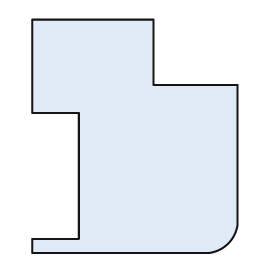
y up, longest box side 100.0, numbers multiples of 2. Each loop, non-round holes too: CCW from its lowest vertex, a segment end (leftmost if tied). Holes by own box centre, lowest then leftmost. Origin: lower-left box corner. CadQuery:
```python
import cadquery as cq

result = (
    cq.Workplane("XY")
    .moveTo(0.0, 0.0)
    .lineTo(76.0, 0.0)
    .threePointArc((84.0, 4.0), (88.0, 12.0))
    .lineTo(88.0, 72.0)
    .lineTo(52.0, 72.0)
    .lineTo(52.0, 100.0)
    .lineTo(0.0, 100.0)
    .lineTo(0.0, 60.0)
    .lineTo(20.0, 60.0)
    .lineTo(20.0, 6.0)
    .lineTo(0.0, 6.0)
    .close()
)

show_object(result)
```